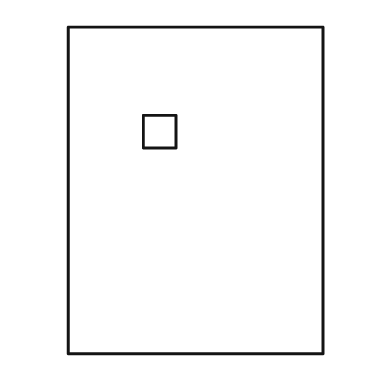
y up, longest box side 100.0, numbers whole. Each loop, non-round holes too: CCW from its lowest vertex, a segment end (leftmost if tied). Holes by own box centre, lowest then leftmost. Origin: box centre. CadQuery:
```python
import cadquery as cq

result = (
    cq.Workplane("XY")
    .moveTo(-39.0, -50.0)
    .lineTo(39.0, -50.0)
    .lineTo(39.0, 50.0)
    .lineTo(-39.0, 50.0)
    .close()
    .moveTo(-16.0, 13.0)
    .lineTo(-6.0, 13.0)
    .lineTo(-6.0, 23.0)
    .lineTo(-16.0, 23.0)
    .close()
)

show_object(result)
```